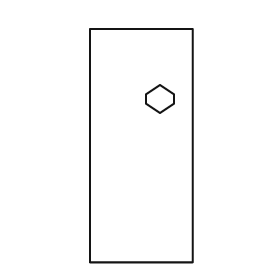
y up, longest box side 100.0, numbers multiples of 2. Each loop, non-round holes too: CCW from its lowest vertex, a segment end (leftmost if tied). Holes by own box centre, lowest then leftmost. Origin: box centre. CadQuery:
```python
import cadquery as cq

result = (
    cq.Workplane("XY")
    .moveTo(-22.0, -50.0)
    .lineTo(22.0, -50.0)
    .lineTo(22.0, 50.0)
    .lineTo(-22.0, 50.0)
    .close()
    .moveTo(8.0, 14.0)
    .lineTo(14.0, 18.0)
    .lineTo(14.0, 22.0)
    .lineTo(8.0, 26.0)
    .lineTo(2.0, 22.0)
    .lineTo(2.0, 18.0)
    .close()
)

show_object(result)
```